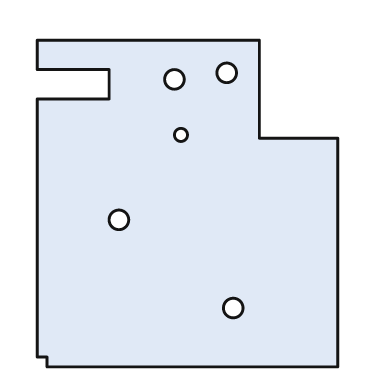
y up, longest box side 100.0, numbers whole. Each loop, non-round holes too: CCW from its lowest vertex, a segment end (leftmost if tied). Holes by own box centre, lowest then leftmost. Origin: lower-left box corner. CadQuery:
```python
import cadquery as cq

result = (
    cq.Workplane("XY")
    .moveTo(3.0, 0.0)
    .lineTo(92.0, 0.0)
    .lineTo(92.0, 70.0)
    .lineTo(68.0, 70.0)
    .lineTo(68.0, 100.0)
    .lineTo(0.0, 100.0)
    .lineTo(0.0, 91.0)
    .lineTo(22.0, 91.0)
    .lineTo(22.0, 82.0)
    .lineTo(0.0, 82.0)
    .lineTo(0.0, 3.0)
    .lineTo(3.0, 3.0)
    .close()
    .moveTo(60.0, 18.0)
    .circle(3.0)
    .moveTo(25.0, 45.0)
    .circle(3.0)
    .moveTo(44.0, 71.0)
    .circle(2.0)
    .moveTo(42.0, 88.0)
    .circle(3.0)
    .moveTo(58.0, 90.0)
    .circle(3.0)
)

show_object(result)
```